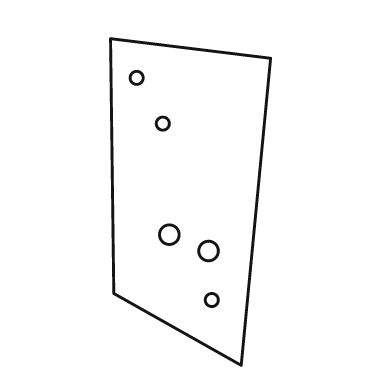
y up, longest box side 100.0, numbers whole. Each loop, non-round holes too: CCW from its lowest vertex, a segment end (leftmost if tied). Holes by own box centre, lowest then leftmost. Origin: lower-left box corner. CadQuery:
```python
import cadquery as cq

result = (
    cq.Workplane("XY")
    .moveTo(40.0, 0.0)
    .lineTo(49.0, 94.0)
    .lineTo(0.0, 100.0)
    .lineTo(1.0, 22.0)
    .close()
    .moveTo(31.0, 20.0)
    .circle(2.0)
    .moveTo(30.0, 35.0)
    .circle(3.0)
    .moveTo(18.0, 40.0)
    .circle(3.0)
    .moveTo(16.0, 74.0)
    .circle(2.0)
    .moveTo(8.0, 88.0)
    .circle(2.0)
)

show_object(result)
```